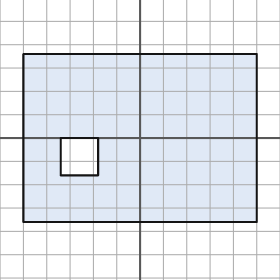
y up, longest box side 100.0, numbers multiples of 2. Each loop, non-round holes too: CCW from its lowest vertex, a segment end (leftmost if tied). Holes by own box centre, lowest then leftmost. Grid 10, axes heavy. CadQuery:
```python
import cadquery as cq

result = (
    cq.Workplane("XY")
    .moveTo(-50.0, -36.0)
    .lineTo(50.0, -36.0)
    .lineTo(50.0, 36.0)
    .lineTo(-50.0, 36.0)
    .close()
    .moveTo(-34.0, -16.0)
    .lineTo(-18.0, -16.0)
    .lineTo(-18.0, 0.0)
    .lineTo(-34.0, 0.0)
    .close()
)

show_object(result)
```